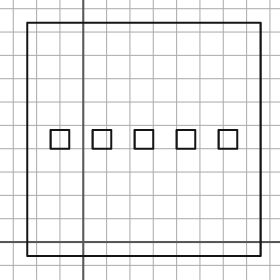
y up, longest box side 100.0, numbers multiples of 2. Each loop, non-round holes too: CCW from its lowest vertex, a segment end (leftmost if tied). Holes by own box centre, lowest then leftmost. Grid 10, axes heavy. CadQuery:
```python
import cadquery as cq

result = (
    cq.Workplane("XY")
    .moveTo(-24.0, -6.0)
    .lineTo(76.0, -6.0)
    .lineTo(76.0, 94.0)
    .lineTo(-24.0, 94.0)
    .close()
    .moveTo(-14.0, 40.0)
    .lineTo(-6.0, 40.0)
    .lineTo(-6.0, 48.0)
    .lineTo(-14.0, 48.0)
    .close()
    .moveTo(4.0, 40.0)
    .lineTo(12.0, 40.0)
    .lineTo(12.0, 48.0)
    .lineTo(4.0, 48.0)
    .close()
    .moveTo(22.0, 40.0)
    .lineTo(30.0, 40.0)
    .lineTo(30.0, 48.0)
    .lineTo(22.0, 48.0)
    .close()
    .moveTo(40.0, 40.0)
    .lineTo(48.0, 40.0)
    .lineTo(48.0, 48.0)
    .lineTo(40.0, 48.0)
    .close()
    .moveTo(58.0, 40.0)
    .lineTo(66.0, 40.0)
    .lineTo(66.0, 48.0)
    .lineTo(58.0, 48.0)
    .close()
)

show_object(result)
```